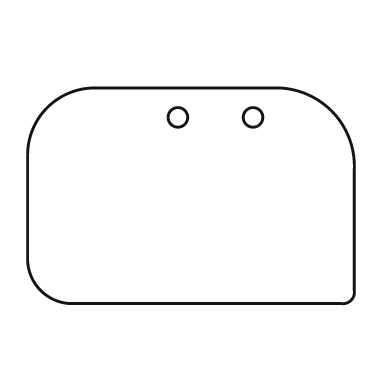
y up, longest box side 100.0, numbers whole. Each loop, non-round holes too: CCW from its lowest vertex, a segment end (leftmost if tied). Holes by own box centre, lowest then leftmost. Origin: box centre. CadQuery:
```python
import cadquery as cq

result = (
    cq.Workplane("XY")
    .moveTo(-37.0, -33.0)
    .lineTo(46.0, -33.0)
    .threePointArc((49.0, -32.0), (50.0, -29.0))
    .lineTo(50.0, 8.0)
    .threePointArc((43.0, 26.0), (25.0, 33.0))
    .lineTo(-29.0, 33.0)
    .threePointArc((-44.0, 27.0), (-50.0, 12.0))
    .lineTo(-50.0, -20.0)
    .threePointArc((-46.0, -29.0), (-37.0, -33.0))
    .close()
    .moveTo(-4.0, 24.0)
    .circle(3.0)
    .moveTo(19.0, 24.0)
    .circle(3.0)
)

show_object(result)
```